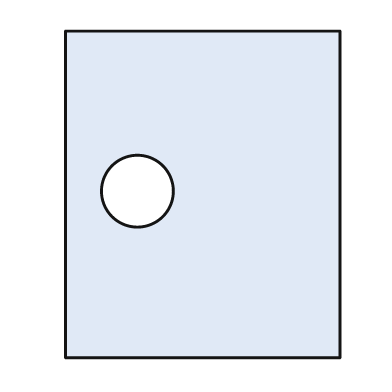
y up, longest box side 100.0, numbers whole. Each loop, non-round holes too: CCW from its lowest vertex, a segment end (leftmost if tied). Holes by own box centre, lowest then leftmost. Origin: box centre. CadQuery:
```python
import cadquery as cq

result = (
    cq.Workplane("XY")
    .moveTo(-42.0, -50.0)
    .lineTo(42.0, -50.0)
    .lineTo(42.0, 50.0)
    .lineTo(-42.0, 50.0)
    .close()
    .moveTo(-20.0, 1.0)
    .circle(11.0)
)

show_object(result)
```